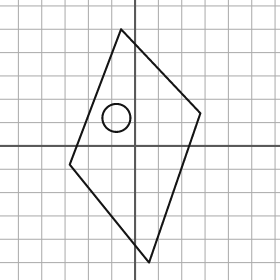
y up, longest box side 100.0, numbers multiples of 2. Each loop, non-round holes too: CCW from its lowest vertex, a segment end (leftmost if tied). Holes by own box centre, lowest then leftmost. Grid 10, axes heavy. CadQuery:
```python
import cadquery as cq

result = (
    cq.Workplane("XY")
    .moveTo(6.0, -50.0)
    .lineTo(28.0, 14.0)
    .lineTo(-6.0, 50.0)
    .lineTo(-28.0, -8.0)
    .close()
    .moveTo(-8.0, 12.0)
    .circle(6.0)
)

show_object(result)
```